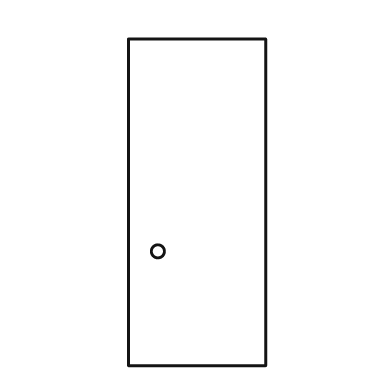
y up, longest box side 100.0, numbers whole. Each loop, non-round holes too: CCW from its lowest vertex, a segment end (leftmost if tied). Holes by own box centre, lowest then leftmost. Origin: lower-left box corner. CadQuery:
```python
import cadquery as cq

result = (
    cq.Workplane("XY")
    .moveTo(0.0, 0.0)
    .lineTo(42.0, 0.0)
    .lineTo(42.0, 100.0)
    .lineTo(0.0, 100.0)
    .close()
    .moveTo(9.0, 35.0)
    .circle(2.0)
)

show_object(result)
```